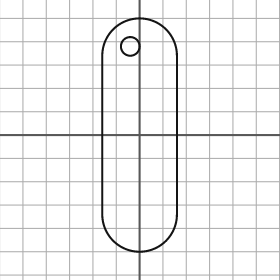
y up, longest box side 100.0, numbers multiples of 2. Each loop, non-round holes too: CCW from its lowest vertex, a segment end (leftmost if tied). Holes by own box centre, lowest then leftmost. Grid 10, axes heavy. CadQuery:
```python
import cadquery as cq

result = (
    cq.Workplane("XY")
    .moveTo(-16.0, -34.0)
    .threePointArc((0.0, -50.0), (16.0, -34.0))
    .lineTo(16.0, 34.0)
    .threePointArc((0.0, 50.0), (-16.0, 34.0))
    .close()
    .moveTo(-4.0, 38.0)
    .circle(4.0)
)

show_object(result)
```